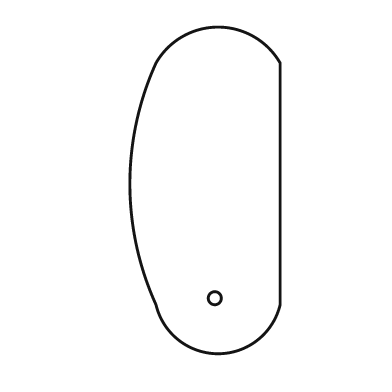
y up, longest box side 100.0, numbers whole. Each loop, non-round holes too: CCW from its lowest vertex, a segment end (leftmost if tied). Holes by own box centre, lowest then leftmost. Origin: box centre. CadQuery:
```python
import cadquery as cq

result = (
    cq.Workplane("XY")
    .moveTo(-15.0, -35.0)
    .threePointArc((4.0, -50.0), (23.0, -35.0))
    .lineTo(23.0, 39.0)
    .threePointArc((4.0, 50.0), (-15.0, 39.0))
    .threePointArc((-23.0, 2.0), (-15.0, -35.0))
    .close()
    .moveTo(3.0, -33.0)
    .circle(2.0)
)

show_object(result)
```